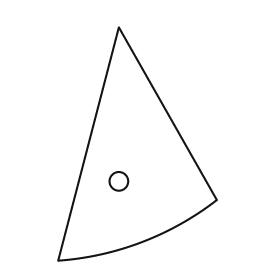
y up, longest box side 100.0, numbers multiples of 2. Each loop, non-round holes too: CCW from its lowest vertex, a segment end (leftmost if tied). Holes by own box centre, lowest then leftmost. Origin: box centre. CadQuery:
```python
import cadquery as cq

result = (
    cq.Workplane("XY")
    .moveTo(-34.0, -50.0)
    .threePointArc((2.0, -42.0), (34.0, -24.0))
    .lineTo(-8.0, 50.0)
    .close()
    .moveTo(-8.0, -16.0)
    .circle(4.0)
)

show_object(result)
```